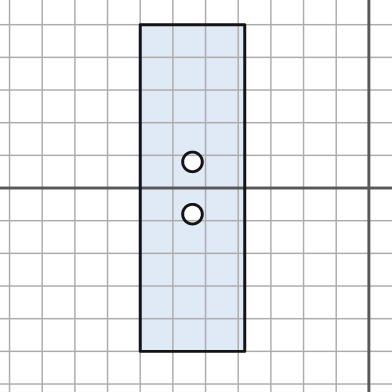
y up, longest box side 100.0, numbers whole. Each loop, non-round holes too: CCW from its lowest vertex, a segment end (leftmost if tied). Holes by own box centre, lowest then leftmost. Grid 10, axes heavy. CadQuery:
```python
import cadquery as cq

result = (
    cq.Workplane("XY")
    .moveTo(-70.0, -50.0)
    .lineTo(-38.0, -50.0)
    .lineTo(-38.0, 50.0)
    .lineTo(-70.0, 50.0)
    .close()
    .moveTo(-54.0, -8.0)
    .circle(3.0)
    .moveTo(-54.0, 8.0)
    .circle(3.0)
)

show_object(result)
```